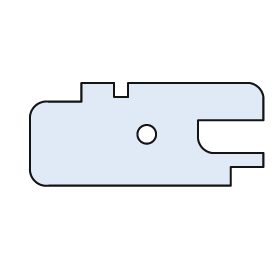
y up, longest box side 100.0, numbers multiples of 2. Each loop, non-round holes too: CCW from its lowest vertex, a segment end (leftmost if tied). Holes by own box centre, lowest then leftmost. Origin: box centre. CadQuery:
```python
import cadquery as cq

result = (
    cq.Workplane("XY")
    .moveTo(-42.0, -22.0)
    .lineTo(36.0, -22.0)
    .lineTo(36.0, -14.0)
    .lineTo(50.0, -14.0)
    .lineTo(50.0, -8.0)
    .lineTo(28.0, -8.0)
    .threePointArc((24.0, -6.0), (22.0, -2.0))
    .lineTo(22.0, 6.0)
    .lineTo(50.0, 6.0)
    .lineTo(50.0, 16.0)
    .threePointArc((48.0, 20.0), (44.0, 22.0))
    .lineTo(-8.0, 22.0)
    .lineTo(-8.0, 16.0)
    .lineTo(-14.0, 16.0)
    .lineTo(-14.0, 22.0)
    .lineTo(-28.0, 22.0)
    .lineTo(-28.0, 14.0)
    .lineTo(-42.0, 14.0)
    .threePointArc((-48.0, 12.0), (-50.0, 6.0))
    .lineTo(-50.0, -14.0)
    .threePointArc((-48.0, -20.0), (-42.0, -22.0))
    .close()
    .moveTo(0.0, 0.0)
    .circle(4.0)
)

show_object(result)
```